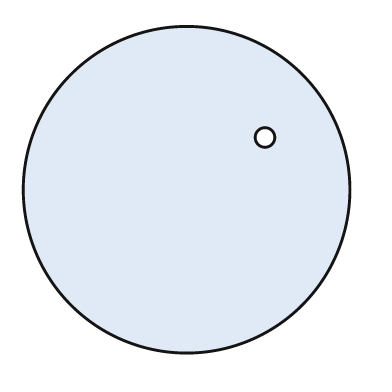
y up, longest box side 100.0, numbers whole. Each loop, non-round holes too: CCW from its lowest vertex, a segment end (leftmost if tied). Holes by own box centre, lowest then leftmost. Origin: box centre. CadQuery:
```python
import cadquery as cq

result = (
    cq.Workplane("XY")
    .moveTo(0.0, 0.0)
    .circle(50.0)
    .moveTo(24.0, 16.0)
    .circle(3.0)
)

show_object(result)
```